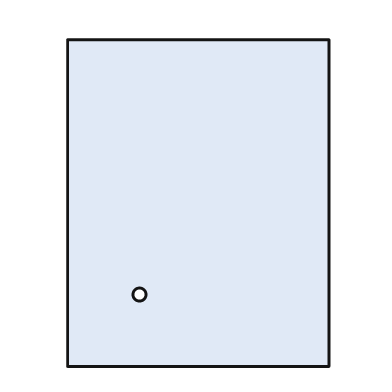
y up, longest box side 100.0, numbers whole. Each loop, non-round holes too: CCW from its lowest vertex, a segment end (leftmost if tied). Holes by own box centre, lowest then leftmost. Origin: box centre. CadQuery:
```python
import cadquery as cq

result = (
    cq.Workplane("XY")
    .moveTo(-40.0, -50.0)
    .lineTo(40.0, -50.0)
    .lineTo(40.0, 50.0)
    .lineTo(-40.0, 50.0)
    .close()
    .moveTo(-18.0, -28.0)
    .circle(2.0)
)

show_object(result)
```